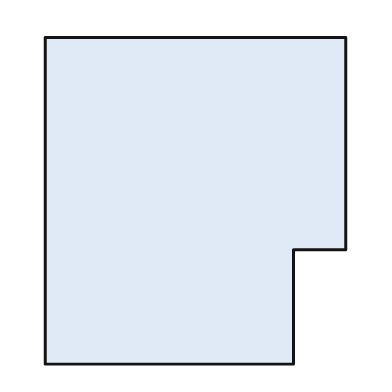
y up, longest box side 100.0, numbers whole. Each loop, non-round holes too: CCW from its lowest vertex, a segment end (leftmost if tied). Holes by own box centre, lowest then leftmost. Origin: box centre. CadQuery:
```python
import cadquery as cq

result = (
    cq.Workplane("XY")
    .moveTo(-46.0, -50.0)
    .lineTo(30.0, -50.0)
    .lineTo(30.0, -15.0)
    .lineTo(46.0, -15.0)
    .lineTo(46.0, 50.0)
    .lineTo(-46.0, 50.0)
    .close()
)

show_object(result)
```